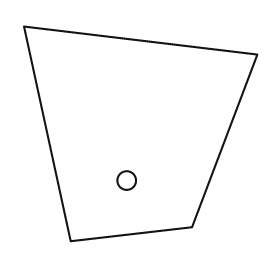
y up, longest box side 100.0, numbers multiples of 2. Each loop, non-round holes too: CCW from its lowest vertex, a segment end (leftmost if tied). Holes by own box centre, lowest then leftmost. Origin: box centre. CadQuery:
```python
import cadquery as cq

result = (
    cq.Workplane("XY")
    .moveTo(-30.0, -46.0)
    .lineTo(22.0, -40.0)
    .lineTo(50.0, 34.0)
    .lineTo(-50.0, 46.0)
    .close()
    .moveTo(-6.0, -20.0)
    .circle(4.0)
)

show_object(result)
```